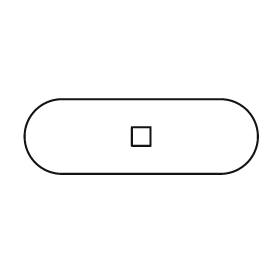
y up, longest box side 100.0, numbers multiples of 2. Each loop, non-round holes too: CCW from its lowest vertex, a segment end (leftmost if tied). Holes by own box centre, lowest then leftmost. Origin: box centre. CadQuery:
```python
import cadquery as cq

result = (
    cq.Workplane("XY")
    .moveTo(-34.0, -16.0)
    .lineTo(34.0, -16.0)
    .threePointArc((50.0, 0.0), (34.0, 16.0))
    .lineTo(-34.0, 16.0)
    .threePointArc((-50.0, 0.0), (-34.0, -16.0))
    .close()
    .moveTo(-4.0, -4.0)
    .lineTo(4.0, -4.0)
    .lineTo(4.0, 4.0)
    .lineTo(-4.0, 4.0)
    .close()
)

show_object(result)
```